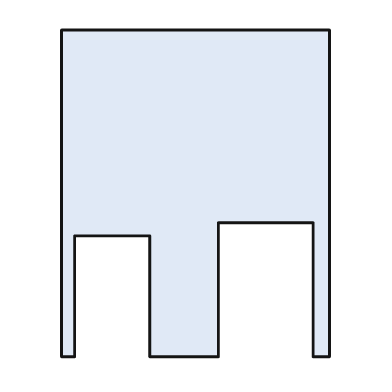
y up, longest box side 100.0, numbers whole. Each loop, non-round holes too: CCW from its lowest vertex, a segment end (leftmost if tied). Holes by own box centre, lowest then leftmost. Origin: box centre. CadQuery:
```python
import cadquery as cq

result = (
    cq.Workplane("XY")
    .moveTo(-41.0, -50.0)
    .lineTo(-37.0, -50.0)
    .lineTo(-37.0, -13.0)
    .lineTo(-14.0, -13.0)
    .lineTo(-14.0, -50.0)
    .lineTo(7.0, -50.0)
    .lineTo(7.0, -9.0)
    .lineTo(36.0, -9.0)
    .lineTo(36.0, -50.0)
    .lineTo(41.0, -50.0)
    .lineTo(41.0, 50.0)
    .lineTo(-41.0, 50.0)
    .close()
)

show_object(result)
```